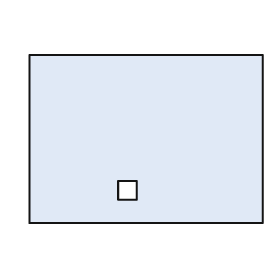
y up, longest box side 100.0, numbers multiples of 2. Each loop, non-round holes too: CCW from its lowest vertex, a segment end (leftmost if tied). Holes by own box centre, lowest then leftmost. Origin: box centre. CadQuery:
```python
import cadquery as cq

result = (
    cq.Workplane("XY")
    .moveTo(-50.0, -36.0)
    .lineTo(50.0, -36.0)
    .lineTo(50.0, 36.0)
    .lineTo(-50.0, 36.0)
    .close()
    .moveTo(-12.0, -26.0)
    .lineTo(-4.0, -26.0)
    .lineTo(-4.0, -18.0)
    .lineTo(-12.0, -18.0)
    .close()
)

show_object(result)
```